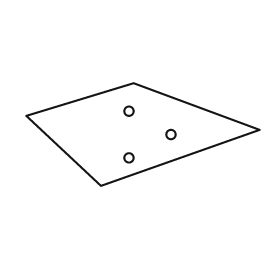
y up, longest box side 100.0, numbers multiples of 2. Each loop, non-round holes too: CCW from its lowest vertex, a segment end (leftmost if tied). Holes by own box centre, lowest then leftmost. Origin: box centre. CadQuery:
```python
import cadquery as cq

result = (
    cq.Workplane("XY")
    .moveTo(-18.0, -22.0)
    .lineTo(50.0, 2.0)
    .lineTo(-4.0, 22.0)
    .lineTo(-50.0, 8.0)
    .close()
    .moveTo(-6.0, -10.0)
    .circle(2.0)
    .moveTo(12.0, 0.0)
    .circle(2.0)
    .moveTo(-6.0, 10.0)
    .circle(2.0)
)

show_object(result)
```